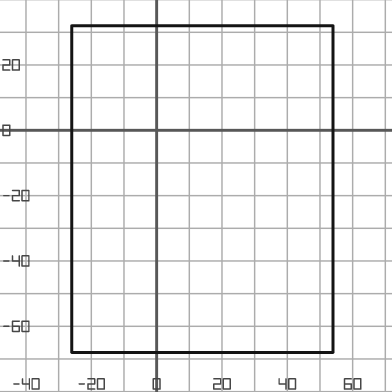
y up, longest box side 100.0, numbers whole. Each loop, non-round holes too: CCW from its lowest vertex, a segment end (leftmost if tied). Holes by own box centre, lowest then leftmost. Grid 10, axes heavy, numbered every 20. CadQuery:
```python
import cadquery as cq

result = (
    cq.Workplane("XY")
    .moveTo(-26.0, -68.0)
    .lineTo(54.0, -68.0)
    .lineTo(54.0, 32.0)
    .lineTo(-26.0, 32.0)
    .close()
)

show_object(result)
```